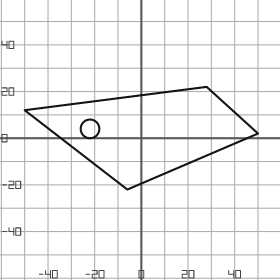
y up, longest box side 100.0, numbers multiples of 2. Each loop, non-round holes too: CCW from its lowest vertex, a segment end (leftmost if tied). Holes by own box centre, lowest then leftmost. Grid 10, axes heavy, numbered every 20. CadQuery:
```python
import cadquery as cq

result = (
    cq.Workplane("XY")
    .moveTo(-6.0, -22.0)
    .lineTo(50.0, 2.0)
    .lineTo(28.0, 22.0)
    .lineTo(-50.0, 12.0)
    .close()
    .moveTo(-22.0, 4.0)
    .circle(4.0)
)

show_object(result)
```